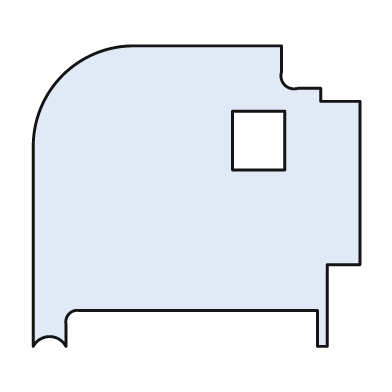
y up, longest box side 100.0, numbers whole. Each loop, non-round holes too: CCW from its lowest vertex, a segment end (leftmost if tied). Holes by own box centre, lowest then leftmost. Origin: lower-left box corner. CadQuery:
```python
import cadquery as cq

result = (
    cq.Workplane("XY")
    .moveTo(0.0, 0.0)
    .threePointArc((5.0, 3.0), (10.0, 0.0))
    .lineTo(10.0, 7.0)
    .threePointArc((11.0, 10.0), (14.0, 11.0))
    .lineTo(87.0, 11.0)
    .lineTo(87.0, 0.0)
    .lineTo(90.0, 0.0)
    .lineTo(90.0, 25.0)
    .lineTo(100.0, 25.0)
    .lineTo(100.0, 75.0)
    .lineTo(88.0, 75.0)
    .lineTo(88.0, 79.0)
    .lineTo(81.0, 79.0)
    .threePointArc((77.0, 80.0), (76.0, 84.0))
    .lineTo(76.0, 92.0)
    .lineTo(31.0, 92.0)
    .threePointArc((9.0, 83.0), (0.0, 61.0))
    .close()
    .moveTo(61.0, 54.0)
    .lineTo(77.0, 54.0)
    .lineTo(77.0, 72.0)
    .lineTo(61.0, 72.0)
    .close()
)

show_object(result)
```